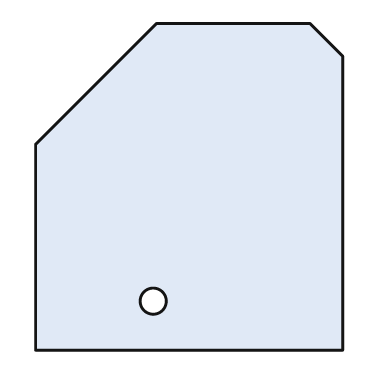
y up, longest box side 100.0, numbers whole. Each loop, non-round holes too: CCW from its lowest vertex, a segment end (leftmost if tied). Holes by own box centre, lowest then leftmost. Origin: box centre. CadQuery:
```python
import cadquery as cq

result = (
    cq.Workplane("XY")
    .moveTo(-47.0, -50.0)
    .lineTo(47.0, -50.0)
    .lineTo(47.0, 40.0)
    .lineTo(37.0, 50.0)
    .lineTo(-10.0, 50.0)
    .lineTo(-47.0, 13.0)
    .close()
    .moveTo(-11.0, -35.0)
    .circle(4.0)
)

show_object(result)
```